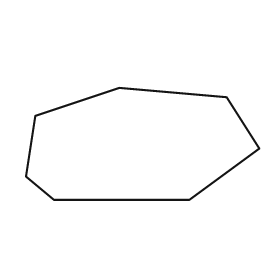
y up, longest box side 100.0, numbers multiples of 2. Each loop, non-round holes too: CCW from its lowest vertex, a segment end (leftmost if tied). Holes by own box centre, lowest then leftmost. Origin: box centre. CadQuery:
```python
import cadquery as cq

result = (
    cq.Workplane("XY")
    .moveTo(-38.0, -24.0)
    .lineTo(20.0, -24.0)
    .lineTo(50.0, -2.0)
    .lineTo(36.0, 20.0)
    .lineTo(-10.0, 24.0)
    .lineTo(-46.0, 12.0)
    .lineTo(-50.0, -14.0)
    .close()
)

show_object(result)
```